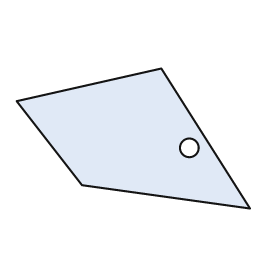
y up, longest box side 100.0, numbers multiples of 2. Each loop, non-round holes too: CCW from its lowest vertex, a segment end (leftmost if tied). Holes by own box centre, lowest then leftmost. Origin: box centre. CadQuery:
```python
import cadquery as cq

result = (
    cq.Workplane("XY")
    .moveTo(50.0, -30.0)
    .lineTo(12.0, 30.0)
    .lineTo(-50.0, 16.0)
    .lineTo(-22.0, -20.0)
    .close()
    .moveTo(24.0, -4.0)
    .circle(4.0)
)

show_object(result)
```